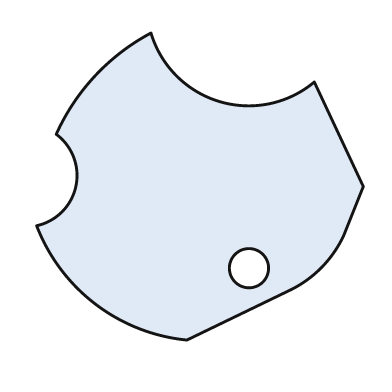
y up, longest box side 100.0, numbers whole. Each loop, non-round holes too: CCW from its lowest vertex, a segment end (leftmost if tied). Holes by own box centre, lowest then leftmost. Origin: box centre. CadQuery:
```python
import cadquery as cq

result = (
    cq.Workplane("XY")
    .moveTo(-4.0, -47.0)
    .lineTo(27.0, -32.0)
    .threePointArc((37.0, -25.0), (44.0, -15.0))
    .lineTo(50.0, 0.0)
    .lineTo(35.0, 32.0)
    .threePointArc((6.0, 26.0), (-15.0, 47.0))
    .threePointArc((-32.0, 34.0), (-44.0, 16.0))
    .threePointArc((-38.0, 0.0), (-50.0, -12.0))
    .threePointArc((-32.0, -36.0), (-4.0, -47.0))
    .close()
    .moveTo(15.0, -25.0)
    .circle(6.0)
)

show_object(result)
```